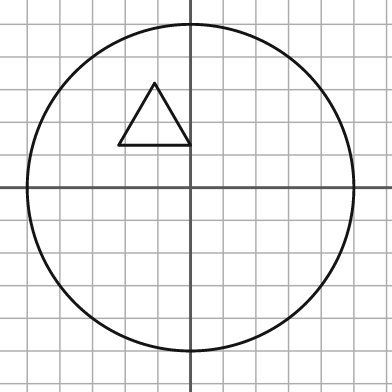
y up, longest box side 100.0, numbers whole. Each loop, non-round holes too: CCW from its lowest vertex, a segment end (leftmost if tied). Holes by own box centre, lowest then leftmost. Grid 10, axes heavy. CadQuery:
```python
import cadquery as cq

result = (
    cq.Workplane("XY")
    .moveTo(0.0, 0.0)
    .circle(50.0)
    .moveTo(-22.0, 13.0)
    .lineTo(0.0, 13.0)
    .lineTo(-11.0, 32.0)
    .close()
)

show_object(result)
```